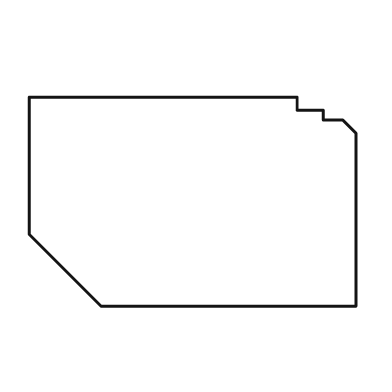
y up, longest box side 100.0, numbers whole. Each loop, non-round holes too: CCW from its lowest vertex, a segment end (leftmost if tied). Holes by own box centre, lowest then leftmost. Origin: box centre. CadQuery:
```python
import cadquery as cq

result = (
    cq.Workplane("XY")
    .moveTo(-28.0, -32.0)
    .lineTo(50.0, -32.0)
    .lineTo(50.0, 21.0)
    .lineTo(46.0, 25.0)
    .lineTo(40.0, 25.0)
    .lineTo(40.0, 28.0)
    .lineTo(32.0, 28.0)
    .lineTo(32.0, 32.0)
    .lineTo(-50.0, 32.0)
    .lineTo(-50.0, -10.0)
    .close()
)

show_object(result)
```